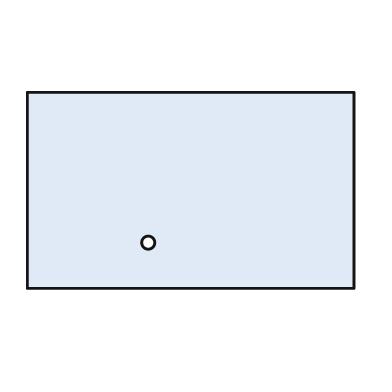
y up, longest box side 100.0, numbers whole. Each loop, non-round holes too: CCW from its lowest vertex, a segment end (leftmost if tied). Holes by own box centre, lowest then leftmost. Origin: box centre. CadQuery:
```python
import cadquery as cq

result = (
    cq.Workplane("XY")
    .moveTo(-50.0, -30.0)
    .lineTo(50.0, -30.0)
    .lineTo(50.0, 30.0)
    .lineTo(-50.0, 30.0)
    .close()
    .moveTo(-13.0, -16.0)
    .circle(2.0)
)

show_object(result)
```